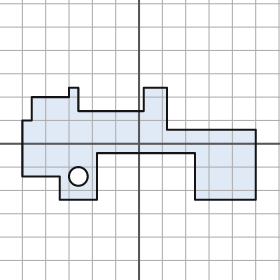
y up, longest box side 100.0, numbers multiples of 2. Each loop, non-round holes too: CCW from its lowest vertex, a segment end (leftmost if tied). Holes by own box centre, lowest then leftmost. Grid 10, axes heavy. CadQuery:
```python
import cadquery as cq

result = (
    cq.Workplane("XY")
    .moveTo(-34.0, -24.0)
    .lineTo(-18.0, -24.0)
    .lineTo(-18.0, -4.0)
    .lineTo(24.0, -4.0)
    .lineTo(24.0, -24.0)
    .lineTo(50.0, -24.0)
    .lineTo(50.0, 6.0)
    .lineTo(12.0, 6.0)
    .lineTo(12.0, 24.0)
    .lineTo(2.0, 24.0)
    .lineTo(2.0, 14.0)
    .lineTo(-26.0, 14.0)
    .lineTo(-26.0, 24.0)
    .lineTo(-30.0, 24.0)
    .lineTo(-30.0, 20.0)
    .lineTo(-46.0, 20.0)
    .lineTo(-46.0, 10.0)
    .lineTo(-50.0, 10.0)
    .lineTo(-50.0, -14.0)
    .lineTo(-34.0, -14.0)
    .close()
    .moveTo(-26.0, -14.0)
    .circle(4.0)
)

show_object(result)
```